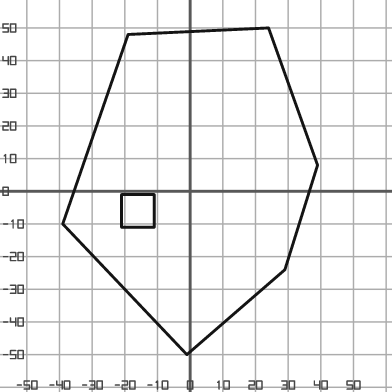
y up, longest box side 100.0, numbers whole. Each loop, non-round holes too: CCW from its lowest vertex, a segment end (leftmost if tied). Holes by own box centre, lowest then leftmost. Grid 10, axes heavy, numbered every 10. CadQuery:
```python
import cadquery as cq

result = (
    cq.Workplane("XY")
    .moveTo(-1.0, -50.0)
    .lineTo(29.0, -24.0)
    .lineTo(39.0, 8.0)
    .lineTo(24.0, 50.0)
    .lineTo(-19.0, 48.0)
    .lineTo(-39.0, -10.0)
    .close()
    .moveTo(-21.0, -11.0)
    .lineTo(-11.0, -11.0)
    .lineTo(-11.0, -1.0)
    .lineTo(-21.0, -1.0)
    .close()
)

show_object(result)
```